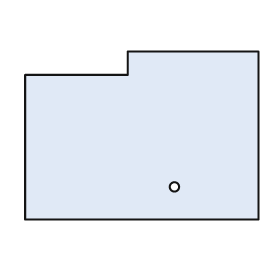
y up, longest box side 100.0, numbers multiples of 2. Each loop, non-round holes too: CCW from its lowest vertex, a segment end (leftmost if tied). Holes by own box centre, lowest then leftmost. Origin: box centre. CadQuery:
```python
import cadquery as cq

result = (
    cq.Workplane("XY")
    .moveTo(-50.0, -36.0)
    .lineTo(50.0, -36.0)
    .lineTo(50.0, 36.0)
    .lineTo(-6.0, 36.0)
    .lineTo(-6.0, 26.0)
    .lineTo(-50.0, 26.0)
    .close()
    .moveTo(14.0, -22.0)
    .circle(2.0)
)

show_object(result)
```